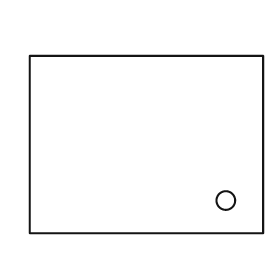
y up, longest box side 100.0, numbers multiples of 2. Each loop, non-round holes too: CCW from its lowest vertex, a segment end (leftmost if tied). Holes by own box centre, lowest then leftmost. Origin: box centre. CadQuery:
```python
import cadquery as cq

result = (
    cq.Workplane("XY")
    .moveTo(-50.0, -38.0)
    .lineTo(50.0, -38.0)
    .lineTo(50.0, 38.0)
    .lineTo(-50.0, 38.0)
    .close()
    .moveTo(34.0, -24.0)
    .circle(4.0)
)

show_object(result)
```